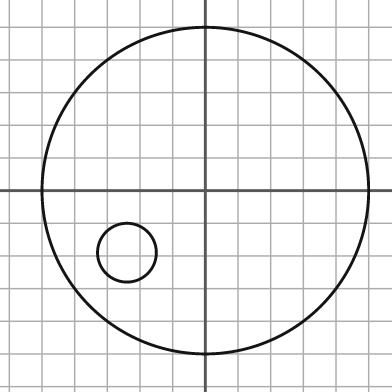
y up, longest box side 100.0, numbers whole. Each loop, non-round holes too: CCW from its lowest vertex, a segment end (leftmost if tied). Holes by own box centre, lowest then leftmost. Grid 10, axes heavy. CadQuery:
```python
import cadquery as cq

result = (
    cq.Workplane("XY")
    .moveTo(0.0, 0.0)
    .circle(50.0)
    .moveTo(-24.0, -19.0)
    .circle(9.0)
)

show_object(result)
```